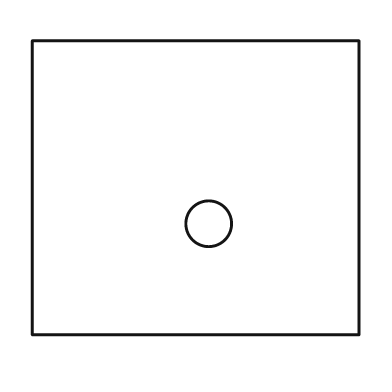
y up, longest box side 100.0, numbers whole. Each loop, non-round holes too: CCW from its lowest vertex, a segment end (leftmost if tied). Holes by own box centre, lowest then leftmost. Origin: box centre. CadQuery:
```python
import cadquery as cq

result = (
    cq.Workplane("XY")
    .moveTo(-50.0, -45.0)
    .lineTo(50.0, -45.0)
    .lineTo(50.0, 45.0)
    .lineTo(-50.0, 45.0)
    .close()
    .moveTo(4.0, -11.0)
    .circle(7.0)
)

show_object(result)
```